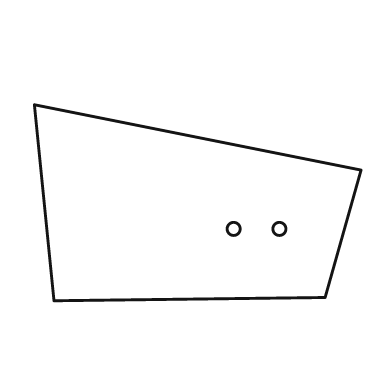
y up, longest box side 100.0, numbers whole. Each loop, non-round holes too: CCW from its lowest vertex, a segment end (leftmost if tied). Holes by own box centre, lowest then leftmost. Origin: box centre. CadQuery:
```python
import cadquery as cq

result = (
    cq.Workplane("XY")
    .moveTo(-44.0, -30.0)
    .lineTo(39.0, -29.0)
    .lineTo(50.0, 10.0)
    .lineTo(-50.0, 30.0)
    .close()
    .moveTo(11.0, -8.0)
    .circle(2.0)
    .moveTo(25.0, -8.0)
    .circle(2.0)
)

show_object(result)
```